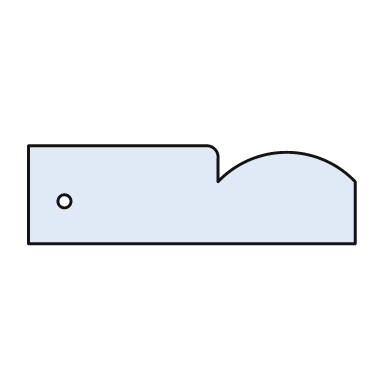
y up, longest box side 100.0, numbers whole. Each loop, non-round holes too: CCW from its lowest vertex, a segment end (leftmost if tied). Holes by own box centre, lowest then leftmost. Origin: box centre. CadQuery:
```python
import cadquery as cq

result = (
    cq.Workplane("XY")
    .moveTo(-50.0, -15.0)
    .lineTo(50.0, -15.0)
    .lineTo(50.0, 4.0)
    .threePointArc((29.0, 13.0), (8.0, 4.0))
    .lineTo(8.0, 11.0)
    .threePointArc((7.0, 14.0), (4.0, 15.0))
    .lineTo(-50.0, 15.0)
    .close()
    .moveTo(-39.0, -2.0)
    .circle(2.0)
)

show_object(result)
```